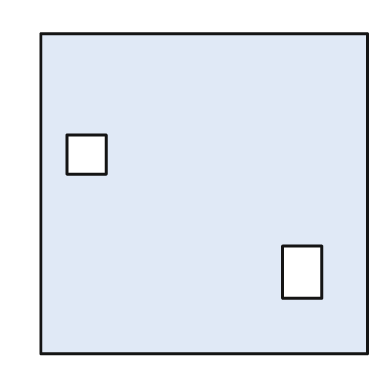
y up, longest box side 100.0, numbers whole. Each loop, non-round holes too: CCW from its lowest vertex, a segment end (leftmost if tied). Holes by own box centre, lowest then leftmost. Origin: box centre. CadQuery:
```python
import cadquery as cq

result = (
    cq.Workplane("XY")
    .moveTo(-50.0, -49.0)
    .lineTo(50.0, -49.0)
    .lineTo(50.0, 49.0)
    .lineTo(-50.0, 49.0)
    .close()
    .moveTo(24.0, -32.0)
    .lineTo(36.0, -32.0)
    .lineTo(36.0, -16.0)
    .lineTo(24.0, -16.0)
    .close()
    .moveTo(-42.0, 6.0)
    .lineTo(-30.0, 6.0)
    .lineTo(-30.0, 18.0)
    .lineTo(-42.0, 18.0)
    .close()
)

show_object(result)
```